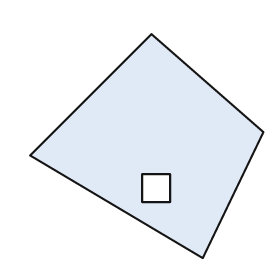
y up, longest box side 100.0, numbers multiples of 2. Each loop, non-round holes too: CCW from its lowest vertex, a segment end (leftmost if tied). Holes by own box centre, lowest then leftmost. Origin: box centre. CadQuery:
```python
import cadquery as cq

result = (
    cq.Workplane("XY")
    .moveTo(24.0, -48.0)
    .lineTo(50.0, 6.0)
    .lineTo(2.0, 48.0)
    .lineTo(-50.0, -4.0)
    .close()
    .moveTo(-2.0, -24.0)
    .lineTo(10.0, -24.0)
    .lineTo(10.0, -12.0)
    .lineTo(-2.0, -12.0)
    .close()
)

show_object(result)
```